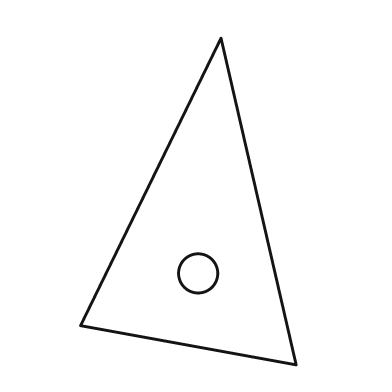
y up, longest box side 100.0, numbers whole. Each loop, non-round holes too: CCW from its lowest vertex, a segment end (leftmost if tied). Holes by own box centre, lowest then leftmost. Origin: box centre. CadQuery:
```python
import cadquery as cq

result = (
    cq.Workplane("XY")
    .moveTo(33.0, -50.0)
    .lineTo(10.0, 50.0)
    .lineTo(-33.0, -38.0)
    .close()
    .moveTo(3.0, -22.0)
    .circle(6.0)
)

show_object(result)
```